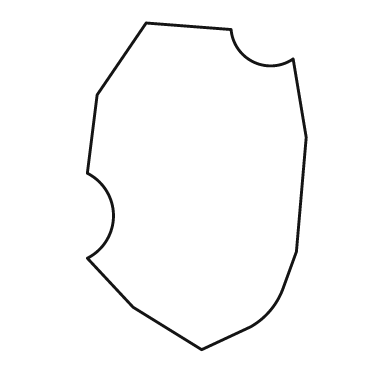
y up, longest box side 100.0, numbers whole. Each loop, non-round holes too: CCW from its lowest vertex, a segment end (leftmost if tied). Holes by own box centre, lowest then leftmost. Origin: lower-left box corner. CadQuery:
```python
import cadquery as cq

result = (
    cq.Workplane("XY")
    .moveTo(35.0, 0.0)
    .lineTo(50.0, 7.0)
    .threePointArc((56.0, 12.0), (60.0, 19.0))
    .lineTo(64.0, 30.0)
    .lineTo(67.0, 65.0)
    .lineTo(63.0, 89.0)
    .threePointArc((51.0, 88.0), (44.0, 98.0))
    .lineTo(18.0, 100.0)
    .lineTo(3.0, 78.0)
    .lineTo(0.0, 54.0)
    .threePointArc((8.0, 41.0), (0.0, 28.0))
    .lineTo(14.0, 13.0)
    .close()
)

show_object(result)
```